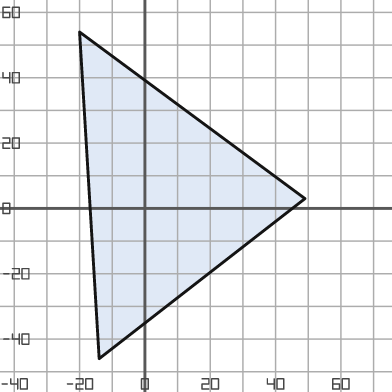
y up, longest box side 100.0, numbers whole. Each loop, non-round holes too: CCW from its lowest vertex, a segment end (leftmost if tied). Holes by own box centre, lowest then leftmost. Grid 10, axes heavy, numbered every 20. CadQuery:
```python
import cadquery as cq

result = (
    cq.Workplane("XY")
    .moveTo(-14.0, -46.0)
    .lineTo(49.0, 3.0)
    .lineTo(-20.0, 54.0)
    .close()
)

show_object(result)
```